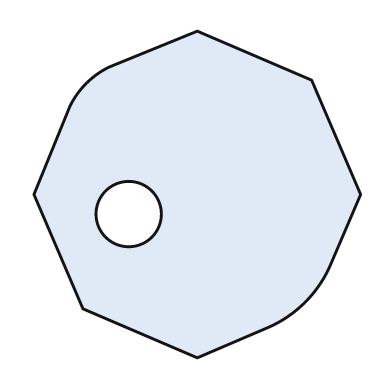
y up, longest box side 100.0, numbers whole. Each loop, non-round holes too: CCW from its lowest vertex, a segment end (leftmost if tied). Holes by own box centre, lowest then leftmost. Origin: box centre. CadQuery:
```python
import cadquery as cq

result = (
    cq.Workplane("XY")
    .moveTo(0.0, -50.0)
    .lineTo(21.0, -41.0)
    .threePointArc((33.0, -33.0), (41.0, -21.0))
    .lineTo(50.0, 0.0)
    .lineTo(35.0, 35.0)
    .lineTo(0.0, 50.0)
    .lineTo(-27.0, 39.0)
    .threePointArc((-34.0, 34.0), (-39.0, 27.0))
    .lineTo(-50.0, 0.0)
    .lineTo(-35.0, -35.0)
    .close()
    .moveTo(-21.0, -6.0)
    .circle(10.0)
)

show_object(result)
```